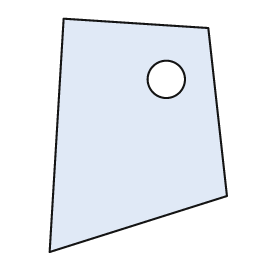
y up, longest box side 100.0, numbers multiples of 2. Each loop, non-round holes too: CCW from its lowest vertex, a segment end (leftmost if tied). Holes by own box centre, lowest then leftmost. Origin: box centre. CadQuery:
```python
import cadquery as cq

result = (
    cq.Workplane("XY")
    .moveTo(-38.0, -50.0)
    .lineTo(38.0, -26.0)
    .lineTo(30.0, 46.0)
    .lineTo(-32.0, 50.0)
    .close()
    .moveTo(12.0, 24.0)
    .circle(8.0)
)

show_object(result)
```